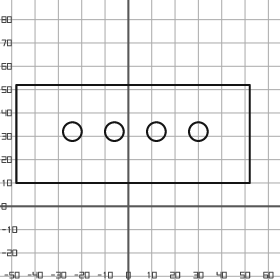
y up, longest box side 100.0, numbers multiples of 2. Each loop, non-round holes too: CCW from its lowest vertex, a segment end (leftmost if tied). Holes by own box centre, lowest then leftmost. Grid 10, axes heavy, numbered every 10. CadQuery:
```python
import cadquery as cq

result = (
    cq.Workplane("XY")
    .moveTo(-48.0, 10.0)
    .lineTo(52.0, 10.0)
    .lineTo(52.0, 52.0)
    .lineTo(-48.0, 52.0)
    .close()
    .moveTo(-24.0, 32.0)
    .circle(4.0)
    .moveTo(-6.0, 32.0)
    .circle(4.0)
    .moveTo(12.0, 32.0)
    .circle(4.0)
    .moveTo(30.0, 32.0)
    .circle(4.0)
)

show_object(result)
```